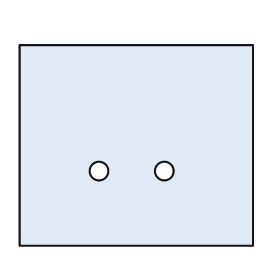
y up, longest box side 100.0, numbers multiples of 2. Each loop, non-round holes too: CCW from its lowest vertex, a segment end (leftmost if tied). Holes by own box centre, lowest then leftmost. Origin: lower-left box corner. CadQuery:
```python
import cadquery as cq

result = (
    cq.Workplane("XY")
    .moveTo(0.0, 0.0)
    .lineTo(100.0, 0.0)
    .lineTo(100.0, 86.0)
    .lineTo(0.0, 86.0)
    .close()
    .moveTo(34.0, 32.0)
    .circle(4.0)
    .moveTo(62.0, 32.0)
    .circle(4.0)
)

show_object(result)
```